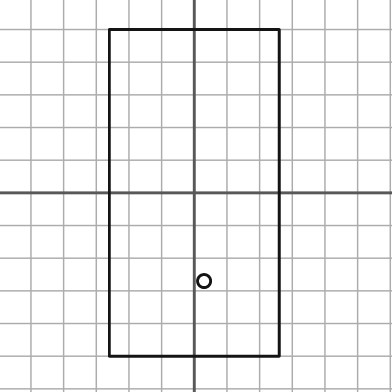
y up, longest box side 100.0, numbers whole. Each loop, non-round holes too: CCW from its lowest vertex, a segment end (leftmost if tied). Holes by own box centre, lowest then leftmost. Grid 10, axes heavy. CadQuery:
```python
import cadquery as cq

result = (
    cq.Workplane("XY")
    .moveTo(-26.0, -50.0)
    .lineTo(26.0, -50.0)
    .lineTo(26.0, 50.0)
    .lineTo(-26.0, 50.0)
    .close()
    .moveTo(3.0, -27.0)
    .circle(2.0)
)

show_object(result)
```